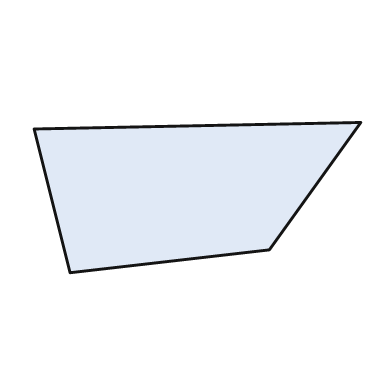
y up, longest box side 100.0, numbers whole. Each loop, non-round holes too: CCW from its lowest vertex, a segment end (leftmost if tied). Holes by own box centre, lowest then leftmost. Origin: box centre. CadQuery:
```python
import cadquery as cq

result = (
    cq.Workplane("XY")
    .moveTo(-39.0, -23.0)
    .lineTo(22.0, -16.0)
    .lineTo(50.0, 23.0)
    .lineTo(-50.0, 21.0)
    .close()
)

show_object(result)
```